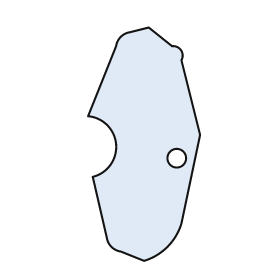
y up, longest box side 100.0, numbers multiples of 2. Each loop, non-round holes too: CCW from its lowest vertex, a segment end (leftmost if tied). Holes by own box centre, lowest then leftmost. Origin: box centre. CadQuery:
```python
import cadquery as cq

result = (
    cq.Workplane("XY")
    .moveTo(0.0, -50.0)
    .threePointArc((10.0, -44.0), (16.0, -34.0))
    .lineTo(24.0, 4.0)
    .lineTo(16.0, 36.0)
    .threePointArc((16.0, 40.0), (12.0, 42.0))
    .lineTo(2.0, 50.0)
    .lineTo(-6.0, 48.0)
    .threePointArc((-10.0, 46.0), (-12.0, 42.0))
    .lineTo(-24.0, 12.0)
    .threePointArc((-12.0, 0.0), (-22.0, -14.0))
    .lineTo(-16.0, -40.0)
    .threePointArc((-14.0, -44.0), (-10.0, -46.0))
    .close()
    .moveTo(14.0, -6.0)
    .circle(4.0)
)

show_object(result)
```